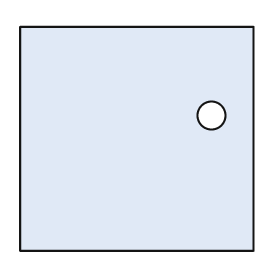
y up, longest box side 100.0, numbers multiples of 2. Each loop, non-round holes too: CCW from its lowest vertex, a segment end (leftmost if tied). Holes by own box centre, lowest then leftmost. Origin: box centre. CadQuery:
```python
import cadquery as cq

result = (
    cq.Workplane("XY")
    .moveTo(-50.0, -48.0)
    .lineTo(50.0, -48.0)
    .lineTo(50.0, 48.0)
    .lineTo(-50.0, 48.0)
    .close()
    .moveTo(32.0, 10.0)
    .circle(6.0)
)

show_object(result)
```